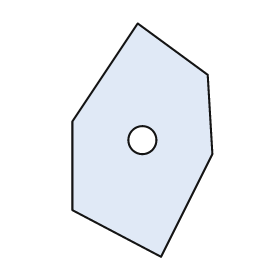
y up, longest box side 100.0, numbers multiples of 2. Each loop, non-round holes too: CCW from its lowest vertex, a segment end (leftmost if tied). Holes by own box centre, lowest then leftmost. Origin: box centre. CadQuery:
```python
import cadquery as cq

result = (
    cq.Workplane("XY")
    .moveTo(8.0, -50.0)
    .lineTo(30.0, -6.0)
    .lineTo(28.0, 28.0)
    .lineTo(-2.0, 50.0)
    .lineTo(-30.0, 8.0)
    .lineTo(-30.0, -30.0)
    .close()
    .moveTo(0.0, 0.0)
    .circle(6.0)
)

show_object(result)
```